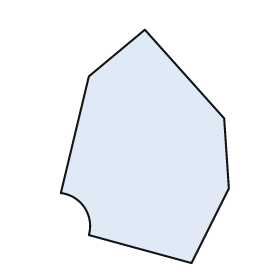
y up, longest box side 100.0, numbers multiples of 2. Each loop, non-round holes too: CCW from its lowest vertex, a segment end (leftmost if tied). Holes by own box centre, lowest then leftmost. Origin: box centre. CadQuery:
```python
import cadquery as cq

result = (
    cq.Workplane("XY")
    .moveTo(20.0, -50.0)
    .lineTo(36.0, -18.0)
    .lineTo(34.0, 12.0)
    .lineTo(0.0, 50.0)
    .lineTo(-24.0, 30.0)
    .lineTo(-36.0, -20.0)
    .threePointArc((-26.0, -26.0), (-24.0, -38.0))
    .close()
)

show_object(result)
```